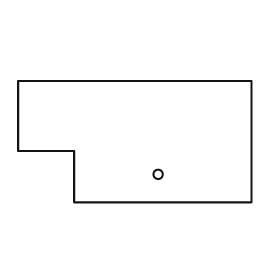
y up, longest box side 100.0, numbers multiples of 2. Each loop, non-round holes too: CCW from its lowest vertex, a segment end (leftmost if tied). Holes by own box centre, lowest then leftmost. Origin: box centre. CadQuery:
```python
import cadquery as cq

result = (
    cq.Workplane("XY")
    .moveTo(-26.0, -26.0)
    .lineTo(50.0, -26.0)
    .lineTo(50.0, 26.0)
    .lineTo(-50.0, 26.0)
    .lineTo(-50.0, -4.0)
    .lineTo(-26.0, -4.0)
    .close()
    .moveTo(10.0, -14.0)
    .circle(2.0)
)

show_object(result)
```